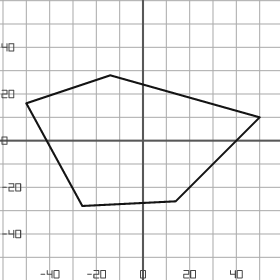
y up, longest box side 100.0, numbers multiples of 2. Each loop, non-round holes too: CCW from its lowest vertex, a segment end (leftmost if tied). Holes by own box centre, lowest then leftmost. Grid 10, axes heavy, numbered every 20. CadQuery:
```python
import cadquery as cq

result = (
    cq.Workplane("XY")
    .moveTo(-26.0, -28.0)
    .lineTo(14.0, -26.0)
    .lineTo(50.0, 10.0)
    .lineTo(-14.0, 28.0)
    .lineTo(-50.0, 16.0)
    .close()
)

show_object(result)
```